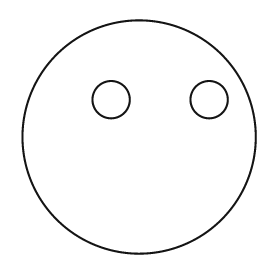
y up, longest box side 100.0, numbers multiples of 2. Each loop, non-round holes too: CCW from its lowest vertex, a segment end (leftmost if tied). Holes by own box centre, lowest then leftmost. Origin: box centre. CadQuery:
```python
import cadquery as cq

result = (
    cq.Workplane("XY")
    .moveTo(0.0, 0.0)
    .circle(50.0)
    .moveTo(-12.0, 16.0)
    .circle(8.0)
    .moveTo(30.0, 16.0)
    .circle(8.0)
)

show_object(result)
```